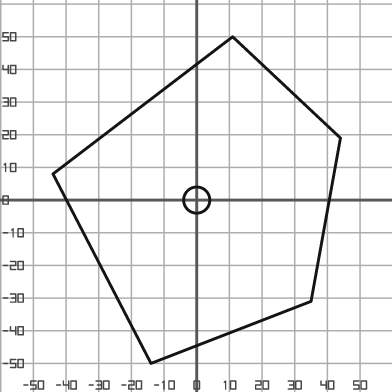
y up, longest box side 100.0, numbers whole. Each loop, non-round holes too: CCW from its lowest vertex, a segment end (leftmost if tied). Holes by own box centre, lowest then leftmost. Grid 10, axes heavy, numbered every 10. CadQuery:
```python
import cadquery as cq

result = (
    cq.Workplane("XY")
    .moveTo(-14.0, -50.0)
    .lineTo(35.0, -31.0)
    .lineTo(44.0, 19.0)
    .lineTo(11.0, 50.0)
    .lineTo(-44.0, 8.0)
    .close()
    .moveTo(0.0, 0.0)
    .circle(4.0)
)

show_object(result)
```